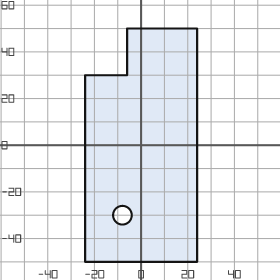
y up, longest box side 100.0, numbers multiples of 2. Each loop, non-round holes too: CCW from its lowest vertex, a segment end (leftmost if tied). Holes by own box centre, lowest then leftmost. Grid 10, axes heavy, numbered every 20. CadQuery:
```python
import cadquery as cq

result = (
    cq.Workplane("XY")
    .moveTo(-24.0, -50.0)
    .lineTo(24.0, -50.0)
    .lineTo(24.0, 50.0)
    .lineTo(-6.0, 50.0)
    .lineTo(-6.0, 30.0)
    .lineTo(-24.0, 30.0)
    .close()
    .moveTo(-8.0, -30.0)
    .circle(4.0)
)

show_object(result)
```